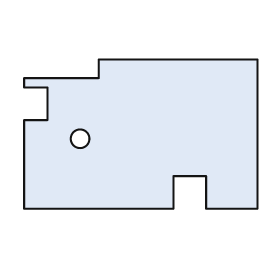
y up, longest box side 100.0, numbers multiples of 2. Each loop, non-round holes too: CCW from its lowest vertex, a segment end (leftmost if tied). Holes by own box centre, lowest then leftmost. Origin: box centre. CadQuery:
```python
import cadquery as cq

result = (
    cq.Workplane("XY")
    .moveTo(-50.0, -32.0)
    .lineTo(14.0, -32.0)
    .lineTo(14.0, -18.0)
    .lineTo(28.0, -18.0)
    .lineTo(28.0, -32.0)
    .lineTo(50.0, -32.0)
    .lineTo(50.0, 32.0)
    .lineTo(-18.0, 32.0)
    .lineTo(-18.0, 24.0)
    .lineTo(-50.0, 24.0)
    .lineTo(-50.0, 20.0)
    .lineTo(-40.0, 20.0)
    .lineTo(-40.0, 6.0)
    .lineTo(-50.0, 6.0)
    .close()
    .moveTo(-26.0, -2.0)
    .circle(4.0)
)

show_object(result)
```